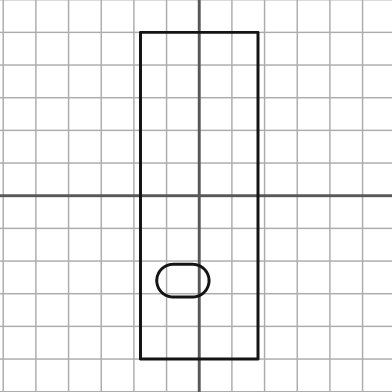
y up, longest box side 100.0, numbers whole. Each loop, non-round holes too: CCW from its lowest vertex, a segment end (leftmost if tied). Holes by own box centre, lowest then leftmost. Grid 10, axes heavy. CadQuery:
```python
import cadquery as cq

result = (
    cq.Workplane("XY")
    .moveTo(-18.0, -50.0)
    .lineTo(18.0, -50.0)
    .lineTo(18.0, 50.0)
    .lineTo(-18.0, 50.0)
    .close()
    .moveTo(-8.0, -31.0)
    .lineTo(-2.0, -31.0)
    .threePointArc((3.0, -26.0), (-2.0, -21.0))
    .lineTo(-8.0, -21.0)
    .threePointArc((-13.0, -26.0), (-8.0, -31.0))
    .close()
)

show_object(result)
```